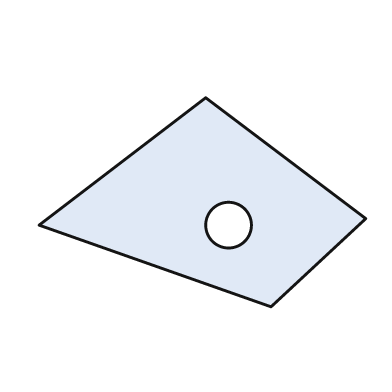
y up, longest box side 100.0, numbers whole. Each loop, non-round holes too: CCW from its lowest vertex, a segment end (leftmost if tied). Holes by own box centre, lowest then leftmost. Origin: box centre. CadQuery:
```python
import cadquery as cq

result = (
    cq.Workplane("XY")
    .moveTo(21.0, -32.0)
    .lineTo(50.0, -5.0)
    .lineTo(1.0, 32.0)
    .lineTo(-50.0, -7.0)
    .close()
    .moveTo(8.0, -7.0)
    .circle(7.0)
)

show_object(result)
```